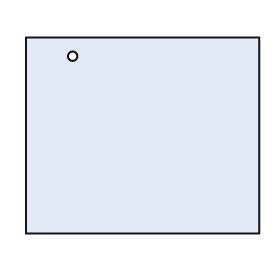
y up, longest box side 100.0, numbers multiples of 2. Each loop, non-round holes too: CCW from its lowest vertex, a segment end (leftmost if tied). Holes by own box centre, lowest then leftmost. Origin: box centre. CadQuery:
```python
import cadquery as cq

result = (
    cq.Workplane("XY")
    .moveTo(-50.0, -42.0)
    .lineTo(50.0, -42.0)
    .lineTo(50.0, 42.0)
    .lineTo(-50.0, 42.0)
    .close()
    .moveTo(-30.0, 34.0)
    .circle(2.0)
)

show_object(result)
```